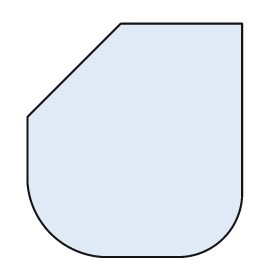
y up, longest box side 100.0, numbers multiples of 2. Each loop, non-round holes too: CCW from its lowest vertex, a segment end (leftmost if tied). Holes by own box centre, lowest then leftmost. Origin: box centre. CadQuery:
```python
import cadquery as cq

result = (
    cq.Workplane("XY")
    .moveTo(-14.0, -50.0)
    .lineTo(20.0, -50.0)
    .threePointArc((38.0, -42.0), (46.0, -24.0))
    .lineTo(46.0, 50.0)
    .lineTo(-6.0, 50.0)
    .lineTo(-46.0, 10.0)
    .lineTo(-46.0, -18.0)
    .threePointArc((-36.0, -40.0), (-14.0, -50.0))
    .close()
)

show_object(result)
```